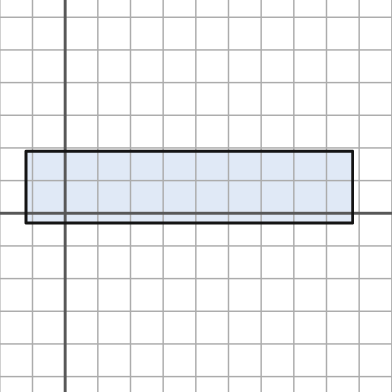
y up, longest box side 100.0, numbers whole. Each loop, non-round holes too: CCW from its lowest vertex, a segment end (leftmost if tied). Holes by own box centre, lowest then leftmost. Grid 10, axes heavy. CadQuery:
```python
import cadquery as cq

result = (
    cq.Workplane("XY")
    .moveTo(-12.0, -3.0)
    .lineTo(88.0, -3.0)
    .lineTo(88.0, 19.0)
    .lineTo(-12.0, 19.0)
    .close()
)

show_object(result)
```